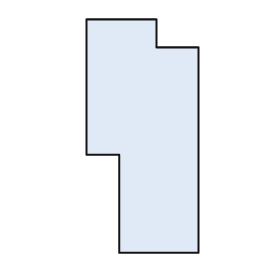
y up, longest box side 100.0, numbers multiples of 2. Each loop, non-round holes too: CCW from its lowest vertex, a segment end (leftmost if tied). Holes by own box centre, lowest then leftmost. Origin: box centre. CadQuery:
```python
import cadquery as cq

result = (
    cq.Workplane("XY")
    .moveTo(-10.0, -50.0)
    .lineTo(24.0, -50.0)
    .lineTo(24.0, 38.0)
    .lineTo(6.0, 38.0)
    .lineTo(6.0, 50.0)
    .lineTo(-24.0, 50.0)
    .lineTo(-24.0, -8.0)
    .lineTo(-10.0, -8.0)
    .close()
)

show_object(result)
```